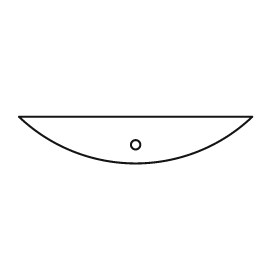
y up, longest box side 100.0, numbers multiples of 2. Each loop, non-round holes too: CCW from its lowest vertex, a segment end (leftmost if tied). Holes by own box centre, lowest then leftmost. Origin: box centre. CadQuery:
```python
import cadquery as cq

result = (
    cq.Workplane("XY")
    .moveTo(-50.0, 10.0)
    .threePointArc((0.0, -10.0), (50.0, 10.0))
    .close()
    .moveTo(0.0, -2.0)
    .circle(2.0)
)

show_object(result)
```